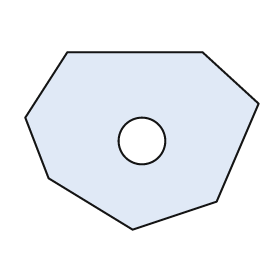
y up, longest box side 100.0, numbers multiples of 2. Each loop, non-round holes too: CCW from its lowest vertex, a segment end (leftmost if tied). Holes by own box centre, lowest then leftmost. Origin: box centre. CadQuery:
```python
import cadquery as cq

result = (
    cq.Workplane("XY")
    .moveTo(-4.0, -38.0)
    .lineTo(32.0, -26.0)
    .lineTo(50.0, 16.0)
    .lineTo(26.0, 38.0)
    .lineTo(-32.0, 38.0)
    .lineTo(-50.0, 10.0)
    .lineTo(-40.0, -16.0)
    .close()
    .moveTo(0.0, 0.0)
    .circle(10.0)
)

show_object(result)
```